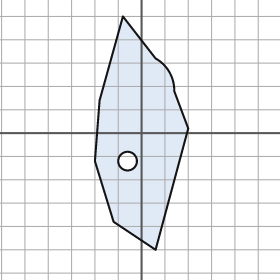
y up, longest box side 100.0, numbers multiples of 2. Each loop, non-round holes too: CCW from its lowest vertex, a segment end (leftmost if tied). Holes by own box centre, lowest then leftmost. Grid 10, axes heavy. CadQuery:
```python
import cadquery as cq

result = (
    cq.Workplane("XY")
    .moveTo(6.0, -50.0)
    .lineTo(20.0, 2.0)
    .lineTo(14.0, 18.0)
    .threePointArc((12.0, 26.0), (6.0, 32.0))
    .lineTo(-8.0, 50.0)
    .lineTo(-18.0, 14.0)
    .lineTo(-20.0, -12.0)
    .lineTo(-12.0, -38.0)
    .close()
    .moveTo(-6.0, -12.0)
    .circle(4.0)
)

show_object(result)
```